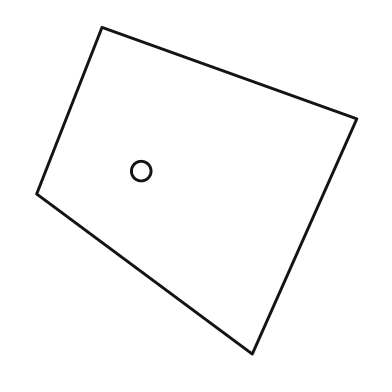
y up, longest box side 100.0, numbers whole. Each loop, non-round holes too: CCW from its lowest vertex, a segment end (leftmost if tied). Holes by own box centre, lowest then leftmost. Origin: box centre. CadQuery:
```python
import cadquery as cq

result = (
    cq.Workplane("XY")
    .moveTo(17.0, -50.0)
    .lineTo(49.0, 22.0)
    .lineTo(-29.0, 50.0)
    .lineTo(-49.0, -1.0)
    .close()
    .moveTo(-17.0, 6.0)
    .circle(3.0)
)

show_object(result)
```